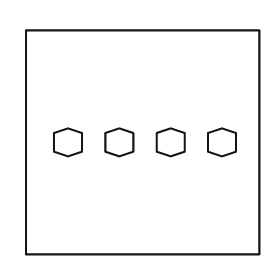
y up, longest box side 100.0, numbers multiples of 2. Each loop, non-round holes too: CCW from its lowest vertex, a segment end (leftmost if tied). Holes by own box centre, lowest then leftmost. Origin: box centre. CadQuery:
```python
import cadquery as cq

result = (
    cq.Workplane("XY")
    .moveTo(-50.0, -48.0)
    .lineTo(50.0, -48.0)
    .lineTo(50.0, 48.0)
    .lineTo(-50.0, 48.0)
    .close()
    .moveTo(-32.0, -6.0)
    .lineTo(-26.0, -4.0)
    .lineTo(-26.0, 4.0)
    .lineTo(-32.0, 6.0)
    .lineTo(-38.0, 4.0)
    .lineTo(-38.0, -4.0)
    .close()
    .moveTo(-10.0, -6.0)
    .lineTo(-4.0, -4.0)
    .lineTo(-4.0, 4.0)
    .lineTo(-10.0, 6.0)
    .lineTo(-16.0, 4.0)
    .lineTo(-16.0, -4.0)
    .close()
    .moveTo(12.0, -6.0)
    .lineTo(18.0, -4.0)
    .lineTo(18.0, 4.0)
    .lineTo(12.0, 6.0)
    .lineTo(6.0, 4.0)
    .lineTo(6.0, -4.0)
    .close()
    .moveTo(34.0, -6.0)
    .lineTo(40.0, -4.0)
    .lineTo(40.0, 4.0)
    .lineTo(34.0, 6.0)
    .lineTo(28.0, 4.0)
    .lineTo(28.0, -4.0)
    .close()
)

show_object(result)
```